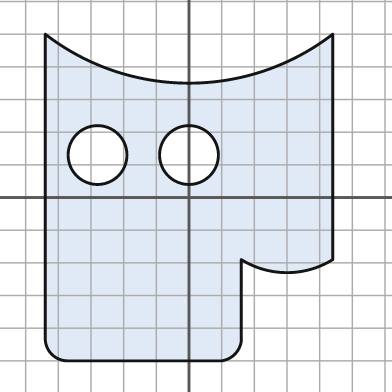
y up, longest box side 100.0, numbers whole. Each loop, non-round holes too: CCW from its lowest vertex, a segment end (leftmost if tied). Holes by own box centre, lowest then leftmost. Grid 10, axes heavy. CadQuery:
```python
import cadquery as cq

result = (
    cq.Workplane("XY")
    .moveTo(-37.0, -50.0)
    .lineTo(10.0, -50.0)
    .threePointArc((14.0, -48.0), (16.0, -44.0))
    .lineTo(16.0, -19.0)
    .threePointArc((30.0, -23.0), (44.0, -19.0))
    .lineTo(44.0, 50.0)
    .threePointArc((0.0, 35.0), (-44.0, 50.0))
    .lineTo(-44.0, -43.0)
    .threePointArc((-42.0, -48.0), (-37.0, -50.0))
    .close()
    .moveTo(-28.0, 13.0)
    .circle(9.0)
    .moveTo(0.0, 13.0)
    .circle(9.0)
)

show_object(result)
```